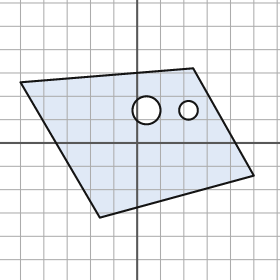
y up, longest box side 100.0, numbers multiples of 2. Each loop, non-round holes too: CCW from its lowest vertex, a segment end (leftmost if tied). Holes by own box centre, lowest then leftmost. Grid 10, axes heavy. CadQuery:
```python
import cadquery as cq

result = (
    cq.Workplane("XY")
    .moveTo(-16.0, -32.0)
    .lineTo(50.0, -14.0)
    .lineTo(24.0, 32.0)
    .lineTo(-50.0, 26.0)
    .close()
    .moveTo(4.0, 14.0)
    .circle(6.0)
    .moveTo(22.0, 14.0)
    .circle(4.0)
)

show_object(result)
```